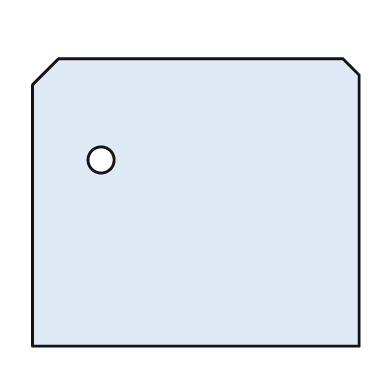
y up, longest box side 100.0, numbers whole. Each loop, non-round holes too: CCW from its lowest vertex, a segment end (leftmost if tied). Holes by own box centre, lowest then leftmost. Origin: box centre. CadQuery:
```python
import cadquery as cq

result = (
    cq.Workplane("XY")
    .moveTo(-50.0, -44.0)
    .lineTo(50.0, -44.0)
    .lineTo(50.0, 39.0)
    .lineTo(45.0, 44.0)
    .lineTo(-42.0, 44.0)
    .lineTo(-50.0, 36.0)
    .close()
    .moveTo(-29.0, 13.0)
    .circle(4.0)
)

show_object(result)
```